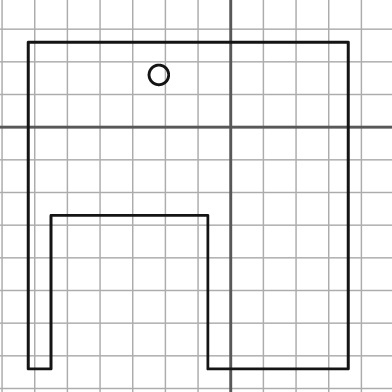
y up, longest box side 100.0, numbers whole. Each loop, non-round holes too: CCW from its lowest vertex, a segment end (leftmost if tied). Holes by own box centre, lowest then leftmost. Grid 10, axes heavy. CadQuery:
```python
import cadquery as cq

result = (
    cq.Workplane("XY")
    .moveTo(-62.0, -74.0)
    .lineTo(-55.0, -74.0)
    .lineTo(-55.0, -27.0)
    .lineTo(-7.0, -27.0)
    .lineTo(-7.0, -74.0)
    .lineTo(36.0, -74.0)
    .lineTo(36.0, 26.0)
    .lineTo(-62.0, 26.0)
    .close()
    .moveTo(-22.0, 16.0)
    .circle(3.0)
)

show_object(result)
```